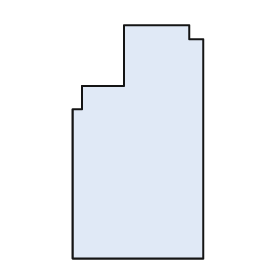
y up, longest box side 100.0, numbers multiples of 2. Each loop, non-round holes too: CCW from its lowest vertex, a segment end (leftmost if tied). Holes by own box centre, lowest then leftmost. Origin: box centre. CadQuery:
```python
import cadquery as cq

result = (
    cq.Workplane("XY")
    .moveTo(-28.0, -50.0)
    .lineTo(28.0, -50.0)
    .lineTo(28.0, 44.0)
    .lineTo(22.0, 44.0)
    .lineTo(22.0, 50.0)
    .lineTo(-6.0, 50.0)
    .lineTo(-6.0, 24.0)
    .lineTo(-24.0, 24.0)
    .lineTo(-24.0, 14.0)
    .lineTo(-28.0, 14.0)
    .close()
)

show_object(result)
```